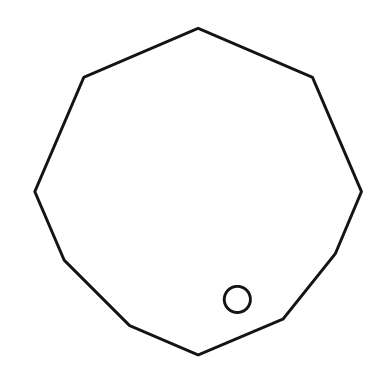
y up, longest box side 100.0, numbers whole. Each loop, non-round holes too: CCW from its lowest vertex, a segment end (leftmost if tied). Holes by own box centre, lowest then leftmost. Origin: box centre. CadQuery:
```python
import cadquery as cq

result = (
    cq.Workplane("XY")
    .moveTo(0.0, -50.0)
    .lineTo(26.0, -39.0)
    .lineTo(42.0, -19.0)
    .lineTo(50.0, 0.0)
    .lineTo(35.0, 35.0)
    .lineTo(0.0, 50.0)
    .lineTo(-35.0, 35.0)
    .lineTo(-50.0, 0.0)
    .lineTo(-41.0, -21.0)
    .lineTo(-21.0, -41.0)
    .close()
    .moveTo(12.0, -33.0)
    .circle(4.0)
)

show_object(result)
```